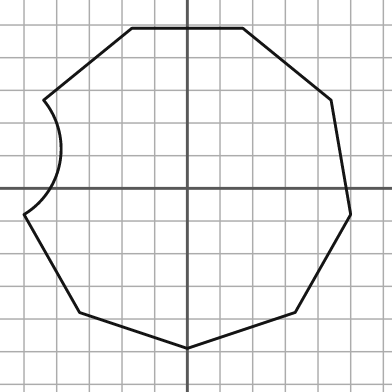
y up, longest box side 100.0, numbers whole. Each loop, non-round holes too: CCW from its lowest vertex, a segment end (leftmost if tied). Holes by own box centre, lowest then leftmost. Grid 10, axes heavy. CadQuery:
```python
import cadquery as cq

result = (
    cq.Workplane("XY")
    .moveTo(0.0, -49.0)
    .lineTo(33.0, -38.0)
    .lineTo(50.0, -8.0)
    .lineTo(44.0, 27.0)
    .lineTo(17.0, 49.0)
    .lineTo(-17.0, 49.0)
    .lineTo(-44.0, 27.0)
    .threePointArc((-39.0, 8.0), (-50.0, -8.0))
    .lineTo(-33.0, -38.0)
    .close()
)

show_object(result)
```